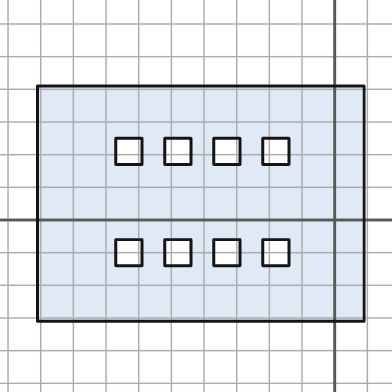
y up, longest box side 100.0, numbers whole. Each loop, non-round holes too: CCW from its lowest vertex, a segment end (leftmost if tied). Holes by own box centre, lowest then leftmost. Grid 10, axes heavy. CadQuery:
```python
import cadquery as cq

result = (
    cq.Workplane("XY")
    .moveTo(-91.0, -31.0)
    .lineTo(9.0, -31.0)
    .lineTo(9.0, 41.0)
    .lineTo(-91.0, 41.0)
    .close()
    .moveTo(-67.0, -14.0)
    .lineTo(-59.0, -14.0)
    .lineTo(-59.0, -6.0)
    .lineTo(-67.0, -6.0)
    .close()
    .moveTo(-52.0, -14.0)
    .lineTo(-44.0, -14.0)
    .lineTo(-44.0, -6.0)
    .lineTo(-52.0, -6.0)
    .close()
    .moveTo(-37.0, -14.0)
    .lineTo(-29.0, -14.0)
    .lineTo(-29.0, -6.0)
    .lineTo(-37.0, -6.0)
    .close()
    .moveTo(-22.0, -14.0)
    .lineTo(-14.0, -14.0)
    .lineTo(-14.0, -6.0)
    .lineTo(-22.0, -6.0)
    .close()
    .moveTo(-67.0, 17.0)
    .lineTo(-59.0, 17.0)
    .lineTo(-59.0, 25.0)
    .lineTo(-67.0, 25.0)
    .close()
    .moveTo(-52.0, 17.0)
    .lineTo(-44.0, 17.0)
    .lineTo(-44.0, 25.0)
    .lineTo(-52.0, 25.0)
    .close()
    .moveTo(-37.0, 17.0)
    .lineTo(-29.0, 17.0)
    .lineTo(-29.0, 25.0)
    .lineTo(-37.0, 25.0)
    .close()
    .moveTo(-22.0, 17.0)
    .lineTo(-14.0, 17.0)
    .lineTo(-14.0, 25.0)
    .lineTo(-22.0, 25.0)
    .close()
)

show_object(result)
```